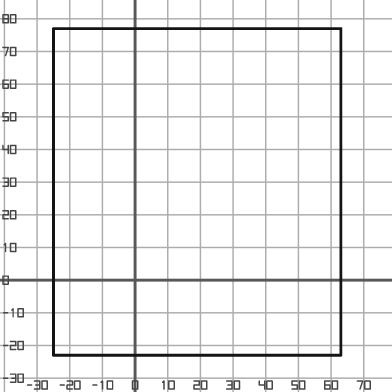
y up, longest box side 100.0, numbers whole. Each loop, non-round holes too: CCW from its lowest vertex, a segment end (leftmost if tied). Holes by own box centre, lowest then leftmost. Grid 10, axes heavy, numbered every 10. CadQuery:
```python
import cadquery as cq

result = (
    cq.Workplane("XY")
    .moveTo(-25.0, -23.0)
    .lineTo(63.0, -23.0)
    .lineTo(63.0, 77.0)
    .lineTo(-25.0, 77.0)
    .close()
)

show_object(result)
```